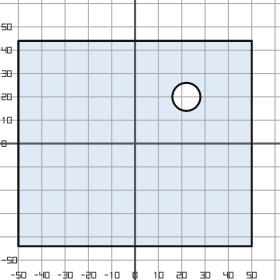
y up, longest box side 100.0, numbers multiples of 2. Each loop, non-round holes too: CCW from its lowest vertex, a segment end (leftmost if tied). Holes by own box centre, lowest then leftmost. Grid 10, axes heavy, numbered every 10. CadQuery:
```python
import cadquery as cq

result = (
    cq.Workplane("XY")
    .moveTo(-50.0, -44.0)
    .lineTo(50.0, -44.0)
    .lineTo(50.0, 44.0)
    .lineTo(-50.0, 44.0)
    .close()
    .moveTo(22.0, 20.0)
    .circle(6.0)
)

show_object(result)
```